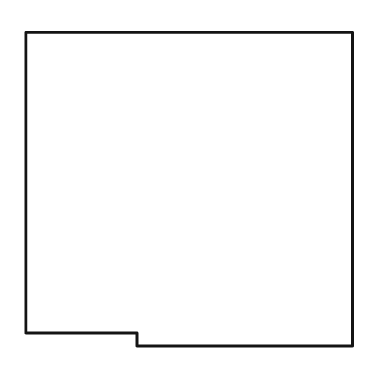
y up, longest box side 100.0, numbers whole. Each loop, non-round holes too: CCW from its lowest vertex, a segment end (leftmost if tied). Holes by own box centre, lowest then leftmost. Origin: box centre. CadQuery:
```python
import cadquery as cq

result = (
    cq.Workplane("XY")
    .moveTo(-16.0, -48.0)
    .lineTo(50.0, -48.0)
    .lineTo(50.0, 48.0)
    .lineTo(-50.0, 48.0)
    .lineTo(-50.0, -44.0)
    .lineTo(-16.0, -44.0)
    .close()
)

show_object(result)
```